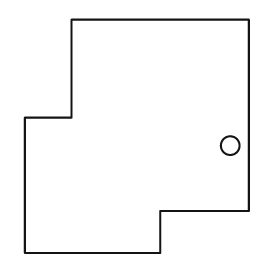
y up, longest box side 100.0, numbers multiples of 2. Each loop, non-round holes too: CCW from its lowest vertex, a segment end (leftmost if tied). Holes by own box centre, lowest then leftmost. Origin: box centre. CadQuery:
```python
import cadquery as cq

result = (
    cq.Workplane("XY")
    .moveTo(-48.0, -50.0)
    .lineTo(10.0, -50.0)
    .lineTo(10.0, -32.0)
    .lineTo(48.0, -32.0)
    .lineTo(48.0, 50.0)
    .lineTo(-28.0, 50.0)
    .lineTo(-28.0, 8.0)
    .lineTo(-48.0, 8.0)
    .close()
    .moveTo(40.0, -4.0)
    .circle(4.0)
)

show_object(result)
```